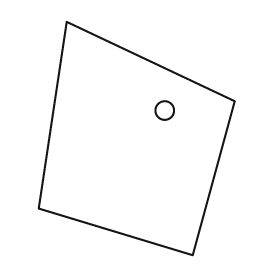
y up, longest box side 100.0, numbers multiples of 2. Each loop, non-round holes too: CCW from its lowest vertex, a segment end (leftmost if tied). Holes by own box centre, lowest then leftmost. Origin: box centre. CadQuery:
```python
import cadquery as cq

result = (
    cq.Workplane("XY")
    .moveTo(24.0, -50.0)
    .lineTo(42.0, 16.0)
    .lineTo(-30.0, 50.0)
    .lineTo(-42.0, -30.0)
    .close()
    .moveTo(12.0, 12.0)
    .circle(4.0)
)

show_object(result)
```